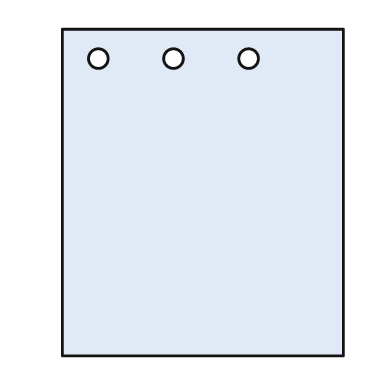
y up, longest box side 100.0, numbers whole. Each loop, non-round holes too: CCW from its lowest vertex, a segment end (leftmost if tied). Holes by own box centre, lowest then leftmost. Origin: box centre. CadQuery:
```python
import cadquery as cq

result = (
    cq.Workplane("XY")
    .moveTo(-43.0, -50.0)
    .lineTo(43.0, -50.0)
    .lineTo(43.0, 50.0)
    .lineTo(-43.0, 50.0)
    .close()
    .moveTo(-32.0, 41.0)
    .circle(3.0)
    .moveTo(-9.0, 41.0)
    .circle(3.0)
    .moveTo(14.0, 41.0)
    .circle(3.0)
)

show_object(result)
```